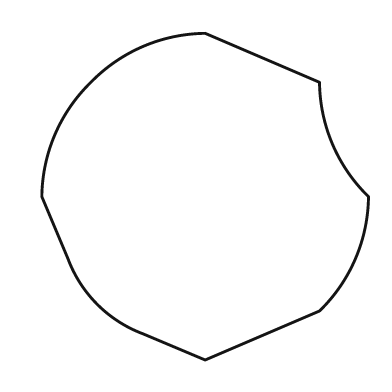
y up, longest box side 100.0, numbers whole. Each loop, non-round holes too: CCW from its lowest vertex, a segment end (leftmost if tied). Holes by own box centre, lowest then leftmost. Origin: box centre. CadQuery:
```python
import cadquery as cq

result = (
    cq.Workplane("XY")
    .moveTo(0.0, -50.0)
    .lineTo(35.0, -35.0)
    .threePointArc((46.0, -19.0), (50.0, 0.0))
    .threePointArc((39.0, 16.0), (35.0, 35.0))
    .lineTo(0.0, 50.0)
    .threePointArc((-19.0, 46.0), (-35.0, 35.0))
    .threePointArc((-46.0, 19.0), (-50.0, 0.0))
    .lineTo(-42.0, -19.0)
    .threePointArc((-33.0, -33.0), (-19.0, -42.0))
    .close()
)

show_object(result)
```